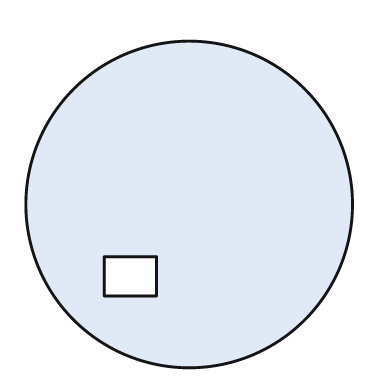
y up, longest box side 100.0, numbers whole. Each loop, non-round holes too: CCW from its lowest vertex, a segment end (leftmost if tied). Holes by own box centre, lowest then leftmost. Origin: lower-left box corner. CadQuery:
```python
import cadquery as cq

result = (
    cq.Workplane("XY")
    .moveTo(50.0, 50.0)
    .circle(50.0)
    .moveTo(24.0, 22.0)
    .lineTo(40.0, 22.0)
    .lineTo(40.0, 34.0)
    .lineTo(24.0, 34.0)
    .close()
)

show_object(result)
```